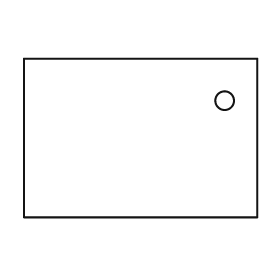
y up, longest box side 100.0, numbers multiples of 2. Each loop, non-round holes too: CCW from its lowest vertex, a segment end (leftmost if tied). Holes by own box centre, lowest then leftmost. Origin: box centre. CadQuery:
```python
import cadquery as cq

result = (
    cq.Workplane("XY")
    .moveTo(-50.0, -34.0)
    .lineTo(50.0, -34.0)
    .lineTo(50.0, 34.0)
    .lineTo(-50.0, 34.0)
    .close()
    .moveTo(36.0, 16.0)
    .circle(4.0)
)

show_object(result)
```